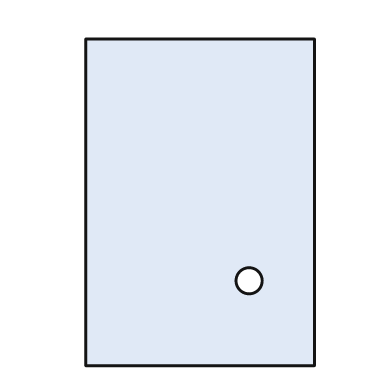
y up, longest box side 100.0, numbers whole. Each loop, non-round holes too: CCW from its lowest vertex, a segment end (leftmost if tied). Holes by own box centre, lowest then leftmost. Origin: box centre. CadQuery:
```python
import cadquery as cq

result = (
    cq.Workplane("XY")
    .moveTo(-35.0, -50.0)
    .lineTo(35.0, -50.0)
    .lineTo(35.0, 50.0)
    .lineTo(-35.0, 50.0)
    .close()
    .moveTo(15.0, -24.0)
    .circle(4.0)
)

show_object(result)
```